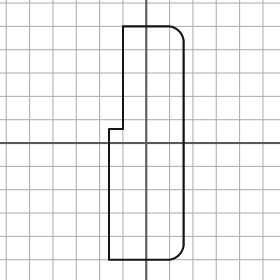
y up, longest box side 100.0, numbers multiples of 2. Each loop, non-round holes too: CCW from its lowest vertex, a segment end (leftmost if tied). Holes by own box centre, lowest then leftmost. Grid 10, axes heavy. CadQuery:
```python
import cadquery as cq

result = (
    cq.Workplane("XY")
    .moveTo(-16.0, -50.0)
    .lineTo(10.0, -50.0)
    .threePointArc((14.0, -48.0), (16.0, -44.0))
    .lineTo(16.0, 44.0)
    .threePointArc((14.0, 48.0), (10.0, 50.0))
    .lineTo(-10.0, 50.0)
    .lineTo(-10.0, 6.0)
    .lineTo(-16.0, 6.0)
    .close()
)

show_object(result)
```